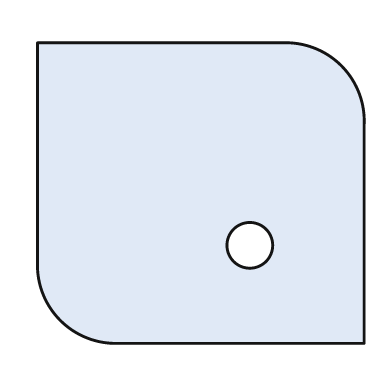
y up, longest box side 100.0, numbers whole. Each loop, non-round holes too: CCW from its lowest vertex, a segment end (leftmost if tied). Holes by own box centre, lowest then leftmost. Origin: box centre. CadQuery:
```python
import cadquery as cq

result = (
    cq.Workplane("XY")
    .moveTo(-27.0, -46.0)
    .lineTo(50.0, -46.0)
    .lineTo(50.0, 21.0)
    .threePointArc((43.0, 39.0), (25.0, 46.0))
    .lineTo(-50.0, 46.0)
    .lineTo(-50.0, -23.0)
    .threePointArc((-43.0, -39.0), (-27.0, -46.0))
    .close()
    .moveTo(15.0, -16.0)
    .circle(7.0)
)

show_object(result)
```